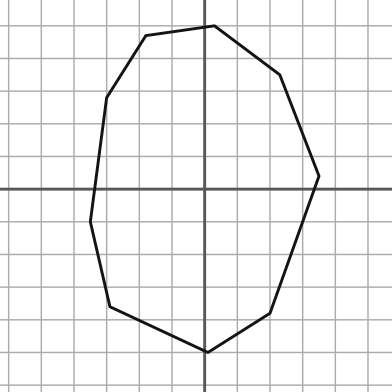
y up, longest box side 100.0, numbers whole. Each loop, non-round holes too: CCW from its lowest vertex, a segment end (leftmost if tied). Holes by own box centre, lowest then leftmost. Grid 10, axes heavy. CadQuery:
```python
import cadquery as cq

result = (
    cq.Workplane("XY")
    .moveTo(1.0, -50.0)
    .lineTo(20.0, -38.0)
    .lineTo(35.0, 4.0)
    .lineTo(23.0, 35.0)
    .lineTo(3.0, 50.0)
    .lineTo(-18.0, 47.0)
    .lineTo(-30.0, 28.0)
    .lineTo(-35.0, -10.0)
    .lineTo(-29.0, -36.0)
    .close()
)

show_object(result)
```